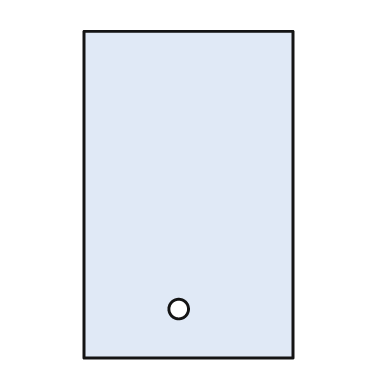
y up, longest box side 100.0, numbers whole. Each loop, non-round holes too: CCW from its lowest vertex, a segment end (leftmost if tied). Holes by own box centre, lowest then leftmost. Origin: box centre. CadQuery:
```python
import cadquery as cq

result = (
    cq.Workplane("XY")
    .moveTo(-32.0, -50.0)
    .lineTo(32.0, -50.0)
    .lineTo(32.0, 50.0)
    .lineTo(-32.0, 50.0)
    .close()
    .moveTo(-3.0, -35.0)
    .circle(3.0)
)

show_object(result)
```